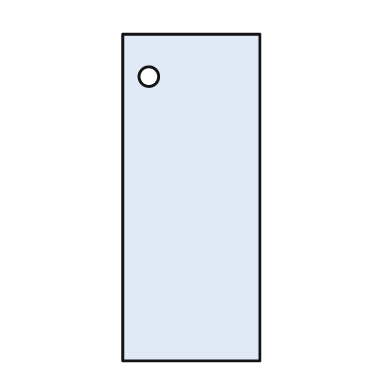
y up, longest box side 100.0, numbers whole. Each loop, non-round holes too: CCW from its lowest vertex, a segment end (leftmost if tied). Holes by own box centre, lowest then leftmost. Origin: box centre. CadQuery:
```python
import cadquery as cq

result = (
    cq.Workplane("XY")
    .moveTo(-21.0, -50.0)
    .lineTo(21.0, -50.0)
    .lineTo(21.0, 50.0)
    .lineTo(-21.0, 50.0)
    .close()
    .moveTo(-13.0, 37.0)
    .circle(3.0)
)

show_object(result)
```